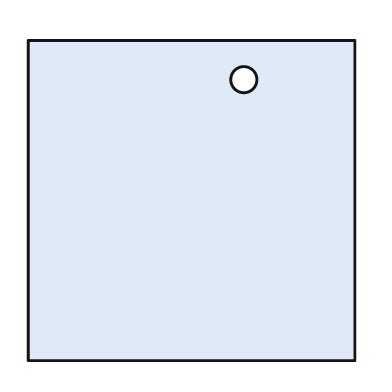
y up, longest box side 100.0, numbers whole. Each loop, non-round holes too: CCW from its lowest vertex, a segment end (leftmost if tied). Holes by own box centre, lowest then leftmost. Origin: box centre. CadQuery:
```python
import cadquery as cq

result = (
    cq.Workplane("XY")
    .moveTo(-50.0, -49.0)
    .lineTo(50.0, -49.0)
    .lineTo(50.0, 49.0)
    .lineTo(-50.0, 49.0)
    .close()
    .moveTo(16.0, 37.0)
    .circle(4.0)
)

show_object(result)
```